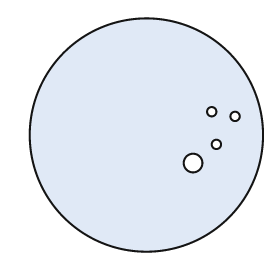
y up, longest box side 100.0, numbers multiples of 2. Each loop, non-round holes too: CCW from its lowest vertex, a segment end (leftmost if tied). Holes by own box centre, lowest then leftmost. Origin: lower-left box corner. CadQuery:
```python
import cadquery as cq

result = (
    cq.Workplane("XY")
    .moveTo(50.0, 50.0)
    .circle(50.0)
    .moveTo(70.0, 38.0)
    .circle(4.0)
    .moveTo(80.0, 46.0)
    .circle(2.0)
    .moveTo(88.0, 58.0)
    .circle(2.0)
    .moveTo(78.0, 60.0)
    .circle(2.0)
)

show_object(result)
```